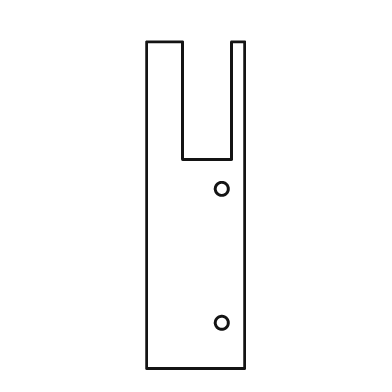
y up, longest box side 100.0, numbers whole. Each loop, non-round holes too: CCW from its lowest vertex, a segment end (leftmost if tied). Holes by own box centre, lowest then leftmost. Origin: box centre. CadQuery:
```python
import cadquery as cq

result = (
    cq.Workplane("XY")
    .moveTo(-15.0, -50.0)
    .lineTo(15.0, -50.0)
    .lineTo(15.0, 50.0)
    .lineTo(11.0, 50.0)
    .lineTo(11.0, 14.0)
    .lineTo(-4.0, 14.0)
    .lineTo(-4.0, 50.0)
    .lineTo(-15.0, 50.0)
    .close()
    .moveTo(8.0, -36.0)
    .circle(2.0)
    .moveTo(8.0, 5.0)
    .circle(2.0)
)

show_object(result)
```